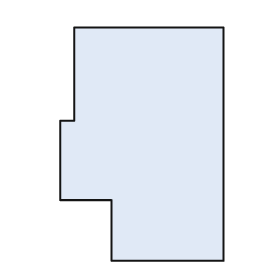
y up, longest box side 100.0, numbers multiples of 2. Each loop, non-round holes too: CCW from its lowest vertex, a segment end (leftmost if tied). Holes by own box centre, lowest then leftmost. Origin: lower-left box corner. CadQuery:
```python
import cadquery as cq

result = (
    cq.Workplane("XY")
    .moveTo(22.0, 0.0)
    .lineTo(70.0, 0.0)
    .lineTo(70.0, 100.0)
    .lineTo(6.0, 100.0)
    .lineTo(6.0, 60.0)
    .lineTo(0.0, 60.0)
    .lineTo(0.0, 26.0)
    .lineTo(22.0, 26.0)
    .close()
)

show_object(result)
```